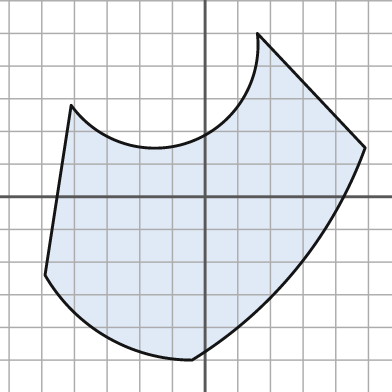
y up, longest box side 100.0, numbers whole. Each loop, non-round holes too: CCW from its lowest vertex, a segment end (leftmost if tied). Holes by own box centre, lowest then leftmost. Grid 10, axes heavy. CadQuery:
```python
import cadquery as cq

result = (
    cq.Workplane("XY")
    .moveTo(-4.0, -50.0)
    .threePointArc((28.0, -22.0), (49.0, 15.0))
    .lineTo(16.0, 50.0)
    .threePointArc((-4.0, 17.0), (-41.0, 28.0))
    .lineTo(-49.0, -24.0)
    .threePointArc((-30.0, -43.0), (-4.0, -50.0))
    .close()
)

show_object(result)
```